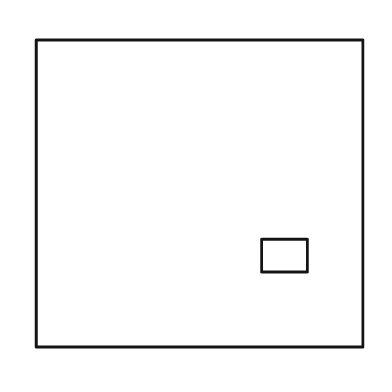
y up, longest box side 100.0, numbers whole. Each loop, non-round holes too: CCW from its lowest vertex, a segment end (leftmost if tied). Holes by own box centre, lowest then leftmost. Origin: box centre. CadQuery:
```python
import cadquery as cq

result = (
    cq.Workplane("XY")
    .moveTo(-50.0, -47.0)
    .lineTo(50.0, -47.0)
    .lineTo(50.0, 47.0)
    .lineTo(-50.0, 47.0)
    .close()
    .moveTo(19.0, -24.0)
    .lineTo(33.0, -24.0)
    .lineTo(33.0, -14.0)
    .lineTo(19.0, -14.0)
    .close()
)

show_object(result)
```